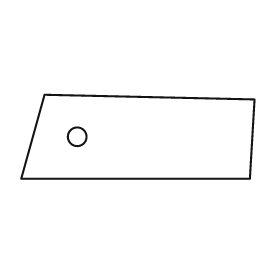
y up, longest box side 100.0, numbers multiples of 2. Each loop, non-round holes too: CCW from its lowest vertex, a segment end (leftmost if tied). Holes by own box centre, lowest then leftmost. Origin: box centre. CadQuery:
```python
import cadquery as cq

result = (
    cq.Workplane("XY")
    .moveTo(-50.0, -18.0)
    .lineTo(48.0, -18.0)
    .lineTo(50.0, 16.0)
    .lineTo(-40.0, 18.0)
    .close()
    .moveTo(-26.0, 0.0)
    .circle(4.0)
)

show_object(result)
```